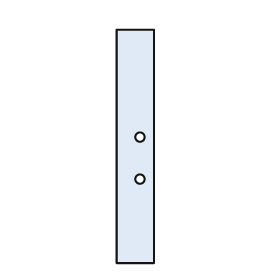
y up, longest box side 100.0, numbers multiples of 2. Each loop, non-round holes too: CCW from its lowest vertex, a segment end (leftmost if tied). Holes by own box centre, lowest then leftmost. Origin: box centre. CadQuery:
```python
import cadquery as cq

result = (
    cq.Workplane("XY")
    .moveTo(-8.0, -50.0)
    .lineTo(8.0, -50.0)
    .lineTo(8.0, 50.0)
    .lineTo(-8.0, 50.0)
    .close()
    .moveTo(2.0, -14.0)
    .circle(2.0)
    .moveTo(2.0, 4.0)
    .circle(2.0)
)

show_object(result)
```